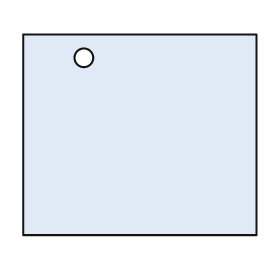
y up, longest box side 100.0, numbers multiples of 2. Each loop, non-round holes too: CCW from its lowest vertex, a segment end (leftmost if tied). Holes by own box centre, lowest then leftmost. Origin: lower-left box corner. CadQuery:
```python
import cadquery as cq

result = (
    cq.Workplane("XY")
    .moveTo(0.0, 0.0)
    .lineTo(100.0, 0.0)
    .lineTo(100.0, 86.0)
    .lineTo(0.0, 86.0)
    .close()
    .moveTo(26.0, 76.0)
    .circle(4.0)
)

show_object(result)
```